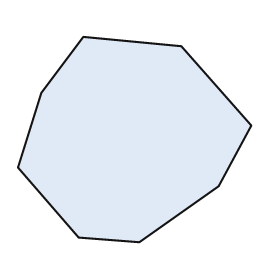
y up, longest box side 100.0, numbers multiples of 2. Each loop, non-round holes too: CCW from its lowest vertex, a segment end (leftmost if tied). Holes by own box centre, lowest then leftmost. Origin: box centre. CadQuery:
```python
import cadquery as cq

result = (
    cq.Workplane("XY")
    .moveTo(2.0, -44.0)
    .lineTo(36.0, -20.0)
    .lineTo(50.0, 6.0)
    .lineTo(20.0, 40.0)
    .lineTo(-22.0, 44.0)
    .lineTo(-40.0, 20.0)
    .lineTo(-50.0, -12.0)
    .lineTo(-24.0, -42.0)
    .close()
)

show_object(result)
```